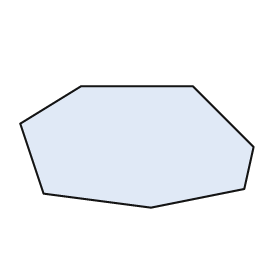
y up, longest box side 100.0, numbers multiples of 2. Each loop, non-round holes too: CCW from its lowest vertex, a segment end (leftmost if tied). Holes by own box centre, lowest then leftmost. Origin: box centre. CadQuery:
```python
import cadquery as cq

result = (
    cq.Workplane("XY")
    .moveTo(6.0, -26.0)
    .lineTo(46.0, -18.0)
    .lineTo(50.0, 0.0)
    .lineTo(24.0, 26.0)
    .lineTo(-24.0, 26.0)
    .lineTo(-50.0, 10.0)
    .lineTo(-40.0, -20.0)
    .close()
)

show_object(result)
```